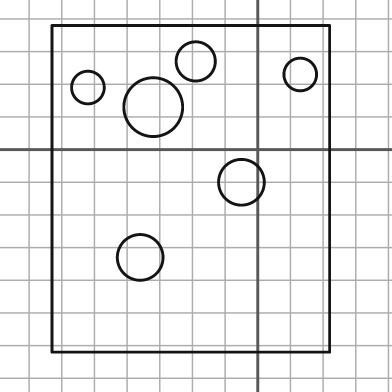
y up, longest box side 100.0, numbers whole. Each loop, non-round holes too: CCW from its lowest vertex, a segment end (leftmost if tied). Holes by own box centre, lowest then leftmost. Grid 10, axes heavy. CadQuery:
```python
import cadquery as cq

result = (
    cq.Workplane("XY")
    .moveTo(-63.0, -62.0)
    .lineTo(22.0, -62.0)
    .lineTo(22.0, 38.0)
    .lineTo(-63.0, 38.0)
    .close()
    .moveTo(-36.0, -33.0)
    .circle(7.0)
    .moveTo(-5.0, -10.0)
    .circle(7.0)
    .moveTo(-32.0, 13.0)
    .circle(9.0)
    .moveTo(-52.0, 19.0)
    .circle(5.0)
    .moveTo(13.0, 23.0)
    .circle(5.0)
    .moveTo(-19.0, 27.0)
    .circle(6.0)
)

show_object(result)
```